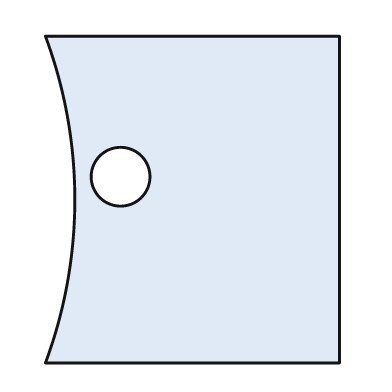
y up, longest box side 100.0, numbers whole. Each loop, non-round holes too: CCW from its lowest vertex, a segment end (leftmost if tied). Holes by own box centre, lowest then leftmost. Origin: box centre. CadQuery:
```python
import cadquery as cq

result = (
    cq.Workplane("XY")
    .moveTo(-45.0, -50.0)
    .lineTo(45.0, -50.0)
    .lineTo(45.0, 50.0)
    .lineTo(-45.0, 50.0)
    .threePointArc((-36.0, 0.0), (-45.0, -50.0))
    .close()
    .moveTo(-22.0, 7.0)
    .circle(9.0)
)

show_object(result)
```